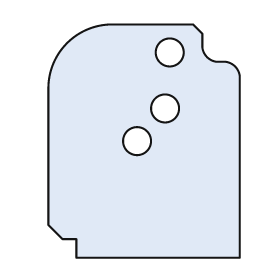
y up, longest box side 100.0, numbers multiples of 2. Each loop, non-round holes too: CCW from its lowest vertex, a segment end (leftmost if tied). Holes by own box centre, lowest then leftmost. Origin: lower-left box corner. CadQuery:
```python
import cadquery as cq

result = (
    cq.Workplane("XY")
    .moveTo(12.0, 0.0)
    .lineTo(82.0, 0.0)
    .lineTo(82.0, 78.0)
    .threePointArc((80.0, 82.0), (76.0, 84.0))
    .lineTo(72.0, 84.0)
    .threePointArc((68.0, 86.0), (66.0, 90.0))
    .lineTo(66.0, 96.0)
    .lineTo(62.0, 100.0)
    .lineTo(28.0, 100.0)
    .threePointArc((8.0, 92.0), (0.0, 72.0))
    .lineTo(0.0, 14.0)
    .lineTo(6.0, 8.0)
    .lineTo(12.0, 8.0)
    .close()
    .moveTo(38.0, 50.0)
    .circle(6.0)
    .moveTo(50.0, 64.0)
    .circle(6.0)
    .moveTo(52.0, 88.0)
    .circle(6.0)
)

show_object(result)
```